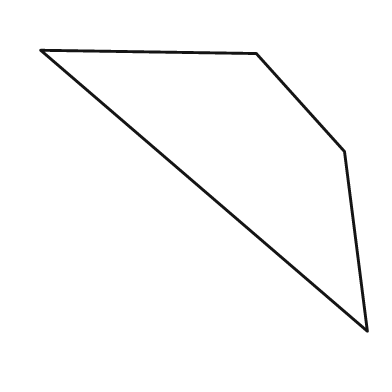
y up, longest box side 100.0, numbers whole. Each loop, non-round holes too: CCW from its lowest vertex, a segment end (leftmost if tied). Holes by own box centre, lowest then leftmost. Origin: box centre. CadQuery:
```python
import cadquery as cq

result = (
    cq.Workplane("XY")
    .moveTo(50.0, -43.0)
    .lineTo(43.0, 12.0)
    .lineTo(16.0, 42.0)
    .lineTo(-50.0, 43.0)
    .close()
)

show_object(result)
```